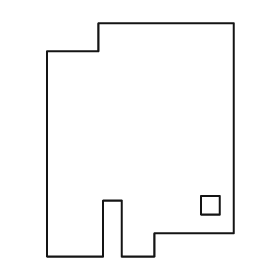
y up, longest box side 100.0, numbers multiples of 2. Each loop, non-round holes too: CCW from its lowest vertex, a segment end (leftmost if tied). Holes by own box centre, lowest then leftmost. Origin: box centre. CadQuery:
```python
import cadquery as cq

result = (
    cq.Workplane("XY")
    .moveTo(-40.0, -50.0)
    .lineTo(-16.0, -50.0)
    .lineTo(-16.0, -26.0)
    .lineTo(-8.0, -26.0)
    .lineTo(-8.0, -50.0)
    .lineTo(6.0, -50.0)
    .lineTo(6.0, -40.0)
    .lineTo(40.0, -40.0)
    .lineTo(40.0, 50.0)
    .lineTo(-18.0, 50.0)
    .lineTo(-18.0, 38.0)
    .lineTo(-40.0, 38.0)
    .close()
    .moveTo(26.0, -32.0)
    .lineTo(34.0, -32.0)
    .lineTo(34.0, -24.0)
    .lineTo(26.0, -24.0)
    .close()
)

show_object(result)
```